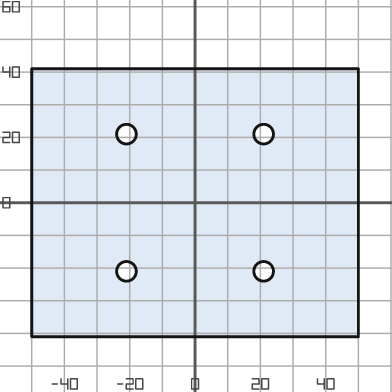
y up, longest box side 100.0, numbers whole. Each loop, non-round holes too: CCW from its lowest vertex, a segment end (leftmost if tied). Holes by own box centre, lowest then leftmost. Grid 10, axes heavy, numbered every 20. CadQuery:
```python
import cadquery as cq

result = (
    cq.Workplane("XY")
    .moveTo(-50.0, -41.0)
    .lineTo(50.0, -41.0)
    .lineTo(50.0, 41.0)
    .lineTo(-50.0, 41.0)
    .close()
    .moveTo(-21.0, -21.0)
    .circle(3.0)
    .moveTo(21.0, -21.0)
    .circle(3.0)
    .moveTo(-21.0, 21.0)
    .circle(3.0)
    .moveTo(21.0, 21.0)
    .circle(3.0)
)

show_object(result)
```